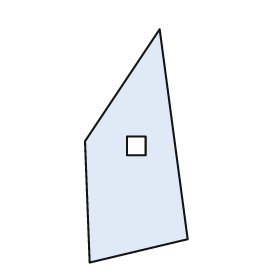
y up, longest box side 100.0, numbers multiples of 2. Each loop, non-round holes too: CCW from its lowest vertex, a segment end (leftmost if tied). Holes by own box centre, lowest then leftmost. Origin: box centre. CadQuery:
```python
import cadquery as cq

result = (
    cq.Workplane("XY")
    .moveTo(-20.0, -50.0)
    .lineTo(22.0, -40.0)
    .lineTo(10.0, 50.0)
    .lineTo(-22.0, 2.0)
    .close()
    .moveTo(-4.0, -4.0)
    .lineTo(4.0, -4.0)
    .lineTo(4.0, 4.0)
    .lineTo(-4.0, 4.0)
    .close()
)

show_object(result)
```